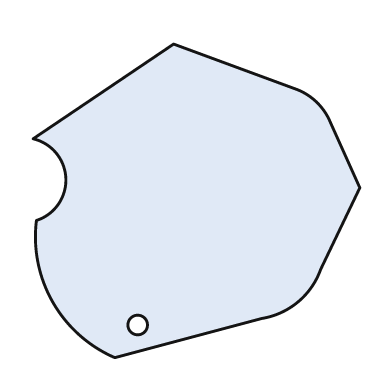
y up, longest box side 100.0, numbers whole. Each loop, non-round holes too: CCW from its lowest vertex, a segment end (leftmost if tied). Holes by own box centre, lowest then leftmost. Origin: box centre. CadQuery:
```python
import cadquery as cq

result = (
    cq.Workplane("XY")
    .moveTo(-25.0, -48.0)
    .lineTo(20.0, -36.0)
    .threePointArc((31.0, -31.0), (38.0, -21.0))
    .lineTo(50.0, 4.0)
    .lineTo(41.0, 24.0)
    .threePointArc((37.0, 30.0), (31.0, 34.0))
    .lineTo(-7.0, 48.0)
    .lineTo(-50.0, 19.0)
    .threePointArc((-40.0, 7.0), (-49.0, -6.0))
    .threePointArc((-44.0, -31.0), (-25.0, -48.0))
    .close()
    .moveTo(-18.0, -38.0)
    .circle(3.0)
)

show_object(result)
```